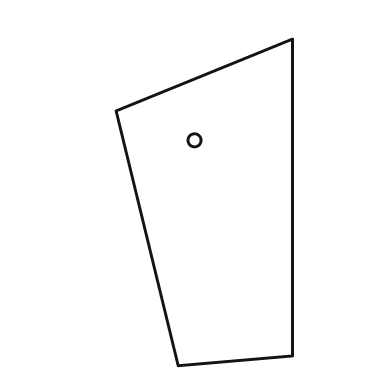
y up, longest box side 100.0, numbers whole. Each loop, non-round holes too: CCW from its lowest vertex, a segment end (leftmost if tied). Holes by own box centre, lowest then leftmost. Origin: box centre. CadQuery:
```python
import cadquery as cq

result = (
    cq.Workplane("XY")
    .moveTo(-8.0, -50.0)
    .lineTo(27.0, -47.0)
    .lineTo(27.0, 50.0)
    .lineTo(-27.0, 28.0)
    .close()
    .moveTo(-3.0, 19.0)
    .circle(2.0)
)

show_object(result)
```